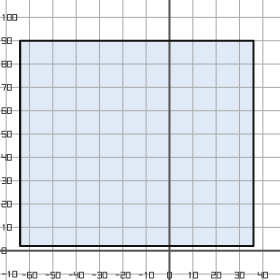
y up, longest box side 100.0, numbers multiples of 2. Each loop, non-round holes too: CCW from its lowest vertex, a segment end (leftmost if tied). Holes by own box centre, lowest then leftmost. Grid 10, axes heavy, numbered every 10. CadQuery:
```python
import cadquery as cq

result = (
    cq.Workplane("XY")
    .moveTo(-64.0, 2.0)
    .lineTo(36.0, 2.0)
    .lineTo(36.0, 90.0)
    .lineTo(-64.0, 90.0)
    .close()
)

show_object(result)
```